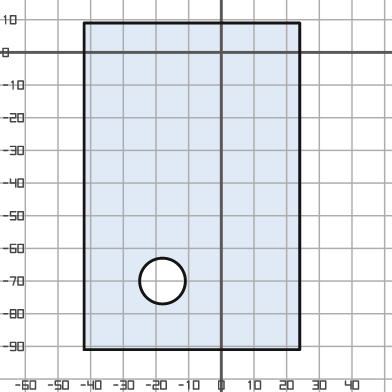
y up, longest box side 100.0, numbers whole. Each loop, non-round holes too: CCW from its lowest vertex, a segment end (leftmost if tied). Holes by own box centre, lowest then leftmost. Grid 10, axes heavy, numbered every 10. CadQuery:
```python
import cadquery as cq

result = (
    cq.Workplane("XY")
    .moveTo(-42.0, -91.0)
    .lineTo(24.0, -91.0)
    .lineTo(24.0, 9.0)
    .lineTo(-42.0, 9.0)
    .close()
    .moveTo(-18.0, -70.0)
    .circle(7.0)
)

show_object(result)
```